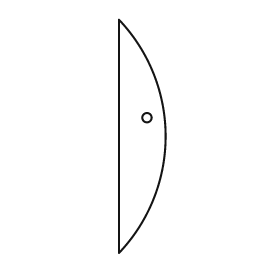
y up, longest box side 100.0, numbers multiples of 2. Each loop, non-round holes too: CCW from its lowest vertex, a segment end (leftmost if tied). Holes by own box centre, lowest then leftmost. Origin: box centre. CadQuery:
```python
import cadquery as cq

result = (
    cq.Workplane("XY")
    .moveTo(-10.0, -50.0)
    .threePointArc((10.0, 0.0), (-10.0, 50.0))
    .close()
    .moveTo(2.0, 8.0)
    .circle(2.0)
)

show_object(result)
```